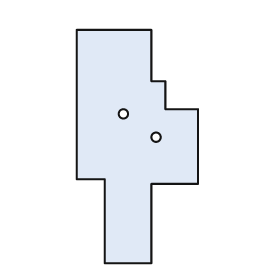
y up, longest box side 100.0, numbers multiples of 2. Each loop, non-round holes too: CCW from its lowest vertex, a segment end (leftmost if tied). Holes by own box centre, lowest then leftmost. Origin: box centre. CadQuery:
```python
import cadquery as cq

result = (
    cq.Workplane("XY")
    .moveTo(-14.0, -50.0)
    .lineTo(6.0, -50.0)
    .lineTo(6.0, -16.0)
    .lineTo(26.0, -16.0)
    .lineTo(26.0, 16.0)
    .lineTo(12.0, 16.0)
    .lineTo(12.0, 28.0)
    .lineTo(6.0, 28.0)
    .lineTo(6.0, 50.0)
    .lineTo(-26.0, 50.0)
    .lineTo(-26.0, -14.0)
    .lineTo(-14.0, -14.0)
    .close()
    .moveTo(8.0, 4.0)
    .circle(2.0)
    .moveTo(-6.0, 14.0)
    .circle(2.0)
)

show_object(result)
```